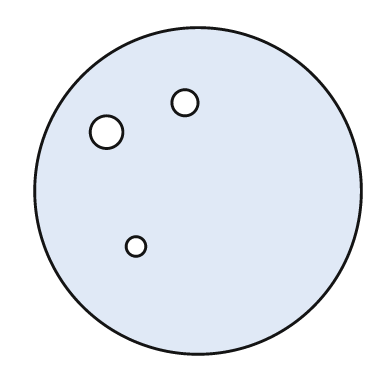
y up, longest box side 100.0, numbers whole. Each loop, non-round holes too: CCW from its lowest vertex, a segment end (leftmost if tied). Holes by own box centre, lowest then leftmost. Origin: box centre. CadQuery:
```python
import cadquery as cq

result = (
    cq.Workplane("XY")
    .moveTo(0.0, 0.0)
    .circle(50.0)
    .moveTo(-19.0, -17.0)
    .circle(3.0)
    .moveTo(-28.0, 18.0)
    .circle(5.0)
    .moveTo(-4.0, 27.0)
    .circle(4.0)
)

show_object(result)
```